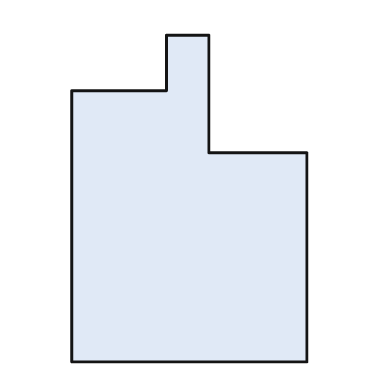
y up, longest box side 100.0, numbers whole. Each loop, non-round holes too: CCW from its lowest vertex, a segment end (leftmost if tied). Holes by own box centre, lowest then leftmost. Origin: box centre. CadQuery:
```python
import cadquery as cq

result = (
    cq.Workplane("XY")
    .moveTo(-36.0, -50.0)
    .lineTo(36.0, -50.0)
    .lineTo(36.0, 14.0)
    .lineTo(6.0, 14.0)
    .lineTo(6.0, 50.0)
    .lineTo(-7.0, 50.0)
    .lineTo(-7.0, 33.0)
    .lineTo(-36.0, 33.0)
    .close()
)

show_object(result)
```